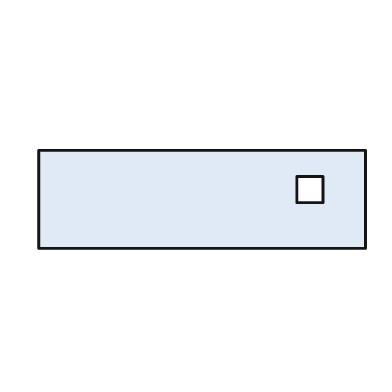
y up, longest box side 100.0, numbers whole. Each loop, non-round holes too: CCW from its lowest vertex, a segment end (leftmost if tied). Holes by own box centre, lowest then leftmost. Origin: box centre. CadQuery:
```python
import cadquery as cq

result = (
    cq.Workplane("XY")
    .moveTo(-50.0, -15.0)
    .lineTo(50.0, -15.0)
    .lineTo(50.0, 15.0)
    .lineTo(-50.0, 15.0)
    .close()
    .moveTo(29.0, -1.0)
    .lineTo(37.0, -1.0)
    .lineTo(37.0, 7.0)
    .lineTo(29.0, 7.0)
    .close()
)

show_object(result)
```